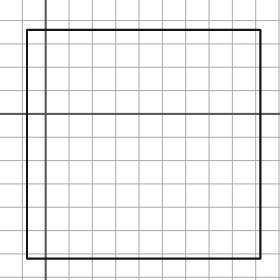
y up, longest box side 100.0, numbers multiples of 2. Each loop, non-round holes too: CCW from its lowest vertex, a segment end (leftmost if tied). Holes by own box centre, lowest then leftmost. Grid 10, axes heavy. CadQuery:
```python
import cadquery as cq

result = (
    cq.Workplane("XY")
    .moveTo(-8.0, -62.0)
    .lineTo(92.0, -62.0)
    .lineTo(92.0, 36.0)
    .lineTo(-8.0, 36.0)
    .close()
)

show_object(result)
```